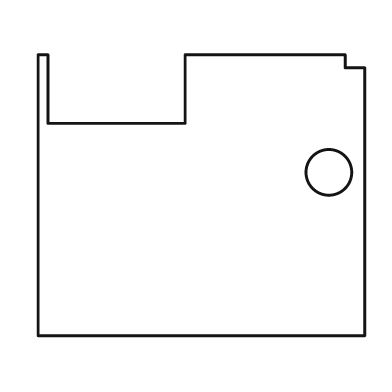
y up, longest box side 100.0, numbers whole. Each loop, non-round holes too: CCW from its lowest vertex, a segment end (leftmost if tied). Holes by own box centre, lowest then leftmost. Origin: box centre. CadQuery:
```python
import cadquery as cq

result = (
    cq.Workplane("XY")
    .moveTo(-50.0, -43.0)
    .lineTo(50.0, -43.0)
    .lineTo(50.0, 39.0)
    .lineTo(44.0, 39.0)
    .lineTo(44.0, 43.0)
    .lineTo(-5.0, 43.0)
    .lineTo(-5.0, 22.0)
    .lineTo(-47.0, 22.0)
    .lineTo(-47.0, 43.0)
    .lineTo(-50.0, 43.0)
    .close()
    .moveTo(39.0, 7.0)
    .circle(7.0)
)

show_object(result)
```